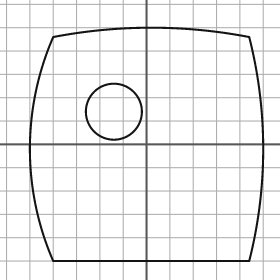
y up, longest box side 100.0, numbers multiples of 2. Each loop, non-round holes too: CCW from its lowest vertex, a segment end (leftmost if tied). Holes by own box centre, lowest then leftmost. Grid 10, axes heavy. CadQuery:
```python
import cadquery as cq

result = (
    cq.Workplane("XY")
    .moveTo(-40.0, -50.0)
    .lineTo(44.0, -50.0)
    .threePointArc((50.0, -2.0), (44.0, 46.0))
    .threePointArc((2.0, 50.0), (-40.0, 46.0))
    .threePointArc((-50.0, -2.0), (-40.0, -50.0))
    .close()
    .moveTo(-14.0, 14.0)
    .circle(12.0)
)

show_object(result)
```